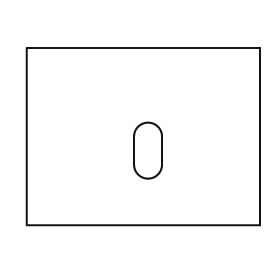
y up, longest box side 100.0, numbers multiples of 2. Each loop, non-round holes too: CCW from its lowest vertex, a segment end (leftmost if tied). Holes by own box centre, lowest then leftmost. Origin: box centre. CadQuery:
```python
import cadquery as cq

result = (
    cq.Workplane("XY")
    .moveTo(-50.0, -38.0)
    .lineTo(50.0, -38.0)
    .lineTo(50.0, 38.0)
    .lineTo(-50.0, 38.0)
    .close()
    .moveTo(-4.0, -12.0)
    .threePointArc((2.0, -18.0), (8.0, -12.0))
    .lineTo(8.0, 0.0)
    .threePointArc((2.0, 6.0), (-4.0, 0.0))
    .close()
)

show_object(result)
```